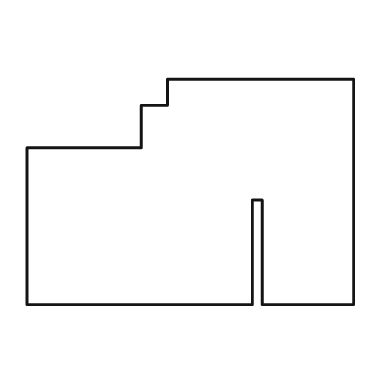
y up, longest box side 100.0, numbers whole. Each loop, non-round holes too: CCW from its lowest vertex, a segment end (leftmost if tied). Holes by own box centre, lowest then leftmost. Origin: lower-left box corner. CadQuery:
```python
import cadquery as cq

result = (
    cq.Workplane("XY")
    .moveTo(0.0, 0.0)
    .lineTo(69.0, 0.0)
    .lineTo(69.0, 32.0)
    .lineTo(72.0, 32.0)
    .lineTo(72.0, 0.0)
    .lineTo(100.0, 0.0)
    .lineTo(100.0, 69.0)
    .lineTo(43.0, 69.0)
    .lineTo(43.0, 61.0)
    .lineTo(35.0, 61.0)
    .lineTo(35.0, 48.0)
    .lineTo(0.0, 48.0)
    .close()
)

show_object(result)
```